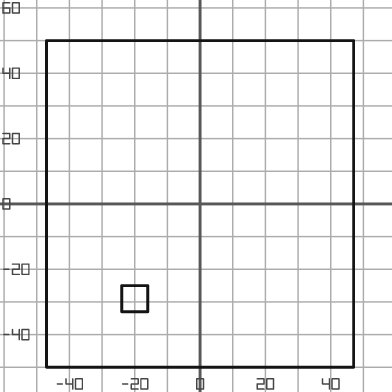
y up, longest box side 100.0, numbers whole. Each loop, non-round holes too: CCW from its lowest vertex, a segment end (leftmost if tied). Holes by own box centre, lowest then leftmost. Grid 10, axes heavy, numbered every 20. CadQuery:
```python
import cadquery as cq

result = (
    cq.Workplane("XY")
    .moveTo(-47.0, -50.0)
    .lineTo(47.0, -50.0)
    .lineTo(47.0, 50.0)
    .lineTo(-47.0, 50.0)
    .close()
    .moveTo(-24.0, -33.0)
    .lineTo(-16.0, -33.0)
    .lineTo(-16.0, -25.0)
    .lineTo(-24.0, -25.0)
    .close()
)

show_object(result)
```